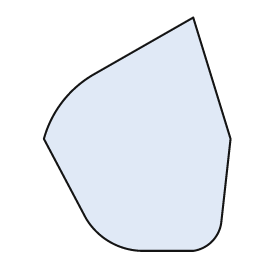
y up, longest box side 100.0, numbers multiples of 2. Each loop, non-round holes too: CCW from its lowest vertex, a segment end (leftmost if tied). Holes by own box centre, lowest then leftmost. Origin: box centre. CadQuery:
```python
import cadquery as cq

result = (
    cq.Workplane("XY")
    .moveTo(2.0, -50.0)
    .lineTo(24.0, -50.0)
    .threePointArc((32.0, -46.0), (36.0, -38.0))
    .lineTo(40.0, -2.0)
    .lineTo(24.0, 50.0)
    .lineTo(-18.0, 26.0)
    .threePointArc((-32.0, 14.0), (-40.0, -2.0))
    .lineTo(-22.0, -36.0)
    .threePointArc((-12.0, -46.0), (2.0, -50.0))
    .close()
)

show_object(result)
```